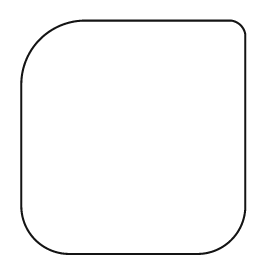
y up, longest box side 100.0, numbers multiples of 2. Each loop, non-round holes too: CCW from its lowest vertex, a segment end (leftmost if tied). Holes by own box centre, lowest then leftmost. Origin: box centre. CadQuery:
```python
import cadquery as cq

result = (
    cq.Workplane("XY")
    .moveTo(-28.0, -50.0)
    .lineTo(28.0, -50.0)
    .threePointArc((42.0, -44.0), (48.0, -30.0))
    .lineTo(48.0, 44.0)
    .threePointArc((46.0, 48.0), (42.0, 50.0))
    .lineTo(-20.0, 50.0)
    .threePointArc((-40.0, 42.0), (-48.0, 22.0))
    .lineTo(-48.0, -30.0)
    .threePointArc((-42.0, -44.0), (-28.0, -50.0))
    .close()
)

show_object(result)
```